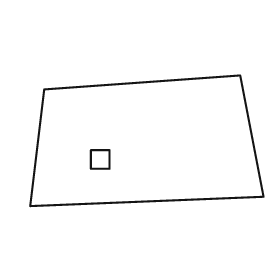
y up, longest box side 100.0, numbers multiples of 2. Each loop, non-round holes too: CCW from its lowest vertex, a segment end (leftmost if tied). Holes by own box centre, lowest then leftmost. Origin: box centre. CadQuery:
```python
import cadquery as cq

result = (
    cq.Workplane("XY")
    .moveTo(-50.0, -28.0)
    .lineTo(50.0, -24.0)
    .lineTo(40.0, 28.0)
    .lineTo(-44.0, 22.0)
    .close()
    .moveTo(-24.0, -12.0)
    .lineTo(-16.0, -12.0)
    .lineTo(-16.0, -4.0)
    .lineTo(-24.0, -4.0)
    .close()
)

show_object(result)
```